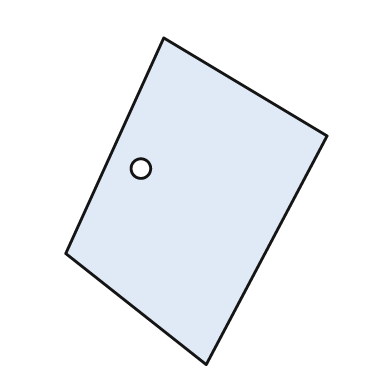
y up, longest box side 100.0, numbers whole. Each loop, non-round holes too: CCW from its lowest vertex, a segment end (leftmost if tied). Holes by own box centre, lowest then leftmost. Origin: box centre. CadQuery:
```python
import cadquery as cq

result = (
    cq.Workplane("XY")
    .moveTo(3.0, -50.0)
    .lineTo(40.0, 20.0)
    .lineTo(-10.0, 50.0)
    .lineTo(-40.0, -16.0)
    .close()
    .moveTo(-17.0, 10.0)
    .circle(3.0)
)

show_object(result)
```